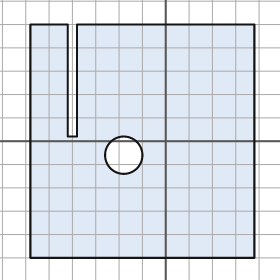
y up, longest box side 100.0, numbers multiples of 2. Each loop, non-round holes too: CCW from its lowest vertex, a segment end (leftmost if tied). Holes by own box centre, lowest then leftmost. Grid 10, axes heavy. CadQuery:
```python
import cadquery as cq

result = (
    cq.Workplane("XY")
    .moveTo(-58.0, -50.0)
    .lineTo(38.0, -50.0)
    .lineTo(38.0, 50.0)
    .lineTo(-38.0, 50.0)
    .lineTo(-38.0, 2.0)
    .lineTo(-42.0, 2.0)
    .lineTo(-42.0, 50.0)
    .lineTo(-58.0, 50.0)
    .close()
    .moveTo(-18.0, -6.0)
    .circle(8.0)
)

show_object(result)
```